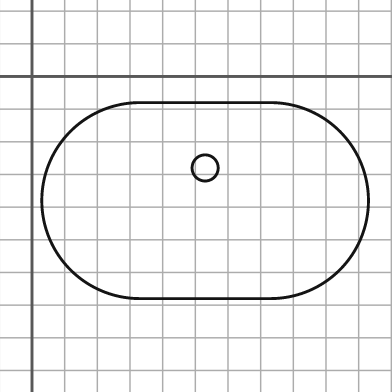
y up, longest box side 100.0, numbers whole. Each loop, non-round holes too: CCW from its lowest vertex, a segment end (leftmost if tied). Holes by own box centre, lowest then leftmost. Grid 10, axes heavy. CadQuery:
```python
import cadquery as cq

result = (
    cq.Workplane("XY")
    .moveTo(33.0, -68.0)
    .lineTo(73.0, -68.0)
    .threePointArc((103.0, -38.0), (73.0, -8.0))
    .lineTo(33.0, -8.0)
    .threePointArc((3.0, -38.0), (33.0, -68.0))
    .close()
    .moveTo(53.0, -28.0)
    .circle(4.0)
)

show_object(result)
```